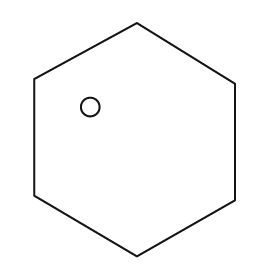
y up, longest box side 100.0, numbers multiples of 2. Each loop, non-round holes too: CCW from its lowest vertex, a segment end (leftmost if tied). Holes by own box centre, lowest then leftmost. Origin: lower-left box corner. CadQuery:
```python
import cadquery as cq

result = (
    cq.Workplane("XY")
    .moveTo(44.0, 0.0)
    .lineTo(86.0, 24.0)
    .lineTo(86.0, 74.0)
    .lineTo(44.0, 100.0)
    .lineTo(0.0, 76.0)
    .lineTo(0.0, 26.0)
    .close()
    .moveTo(24.0, 64.0)
    .circle(4.0)
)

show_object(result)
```